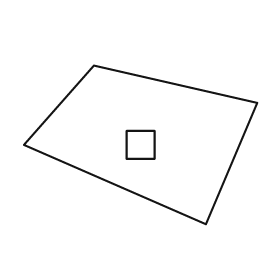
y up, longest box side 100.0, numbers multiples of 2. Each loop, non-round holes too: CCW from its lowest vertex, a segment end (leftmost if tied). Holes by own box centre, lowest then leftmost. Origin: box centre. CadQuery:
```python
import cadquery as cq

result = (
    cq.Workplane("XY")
    .moveTo(28.0, -34.0)
    .lineTo(50.0, 18.0)
    .lineTo(-20.0, 34.0)
    .lineTo(-50.0, 0.0)
    .close()
    .moveTo(-6.0, -6.0)
    .lineTo(6.0, -6.0)
    .lineTo(6.0, 6.0)
    .lineTo(-6.0, 6.0)
    .close()
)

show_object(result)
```